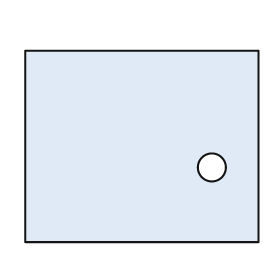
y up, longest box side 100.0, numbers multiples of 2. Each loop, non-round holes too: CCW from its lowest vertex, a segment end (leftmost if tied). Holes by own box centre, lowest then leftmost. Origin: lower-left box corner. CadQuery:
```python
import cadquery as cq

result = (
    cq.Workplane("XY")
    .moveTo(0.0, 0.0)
    .lineTo(100.0, 0.0)
    .lineTo(100.0, 82.0)
    .lineTo(0.0, 82.0)
    .close()
    .moveTo(80.0, 32.0)
    .circle(6.0)
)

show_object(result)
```